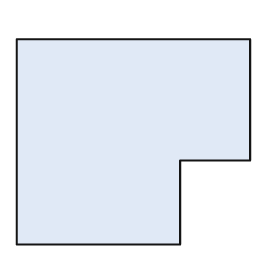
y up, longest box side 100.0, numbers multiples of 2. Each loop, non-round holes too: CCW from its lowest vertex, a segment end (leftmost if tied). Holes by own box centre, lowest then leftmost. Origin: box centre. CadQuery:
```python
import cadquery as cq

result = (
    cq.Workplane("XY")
    .moveTo(-50.0, -44.0)
    .lineTo(20.0, -44.0)
    .lineTo(20.0, -8.0)
    .lineTo(50.0, -8.0)
    .lineTo(50.0, 44.0)
    .lineTo(-50.0, 44.0)
    .close()
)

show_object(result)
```